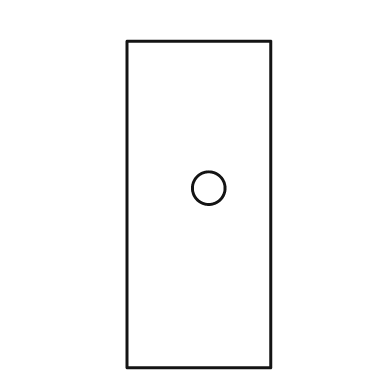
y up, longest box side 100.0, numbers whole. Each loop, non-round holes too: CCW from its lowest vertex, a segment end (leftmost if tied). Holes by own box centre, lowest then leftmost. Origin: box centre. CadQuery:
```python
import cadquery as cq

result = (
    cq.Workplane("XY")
    .moveTo(-22.0, -50.0)
    .lineTo(22.0, -50.0)
    .lineTo(22.0, 50.0)
    .lineTo(-22.0, 50.0)
    .close()
    .moveTo(3.0, 5.0)
    .circle(5.0)
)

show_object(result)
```